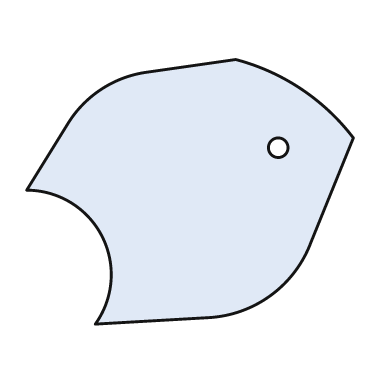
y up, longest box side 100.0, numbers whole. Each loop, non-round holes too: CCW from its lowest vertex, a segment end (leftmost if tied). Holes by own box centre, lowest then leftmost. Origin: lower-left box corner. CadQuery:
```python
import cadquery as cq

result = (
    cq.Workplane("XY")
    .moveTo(21.0, 0.0)
    .lineTo(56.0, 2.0)
    .threePointArc((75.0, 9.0), (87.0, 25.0))
    .lineTo(100.0, 57.0)
    .threePointArc((84.0, 72.0), (64.0, 81.0))
    .lineTo(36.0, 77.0)
    .threePointArc((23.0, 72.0), (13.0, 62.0))
    .lineTo(0.0, 41.0)
    .threePointArc((23.0, 27.0), (21.0, 0.0))
    .close()
    .moveTo(77.0, 54.0)
    .circle(3.0)
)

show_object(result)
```